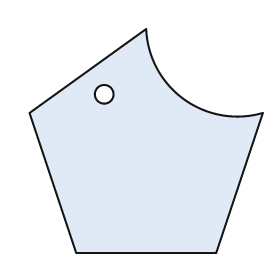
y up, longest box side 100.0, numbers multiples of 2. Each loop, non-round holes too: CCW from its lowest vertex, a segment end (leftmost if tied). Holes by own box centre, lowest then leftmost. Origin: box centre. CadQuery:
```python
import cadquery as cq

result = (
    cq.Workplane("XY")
    .moveTo(-30.0, -48.0)
    .lineTo(30.0, -48.0)
    .lineTo(50.0, 12.0)
    .threePointArc((16.0, 18.0), (0.0, 48.0))
    .lineTo(-50.0, 12.0)
    .close()
    .moveTo(-18.0, 20.0)
    .circle(4.0)
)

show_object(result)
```